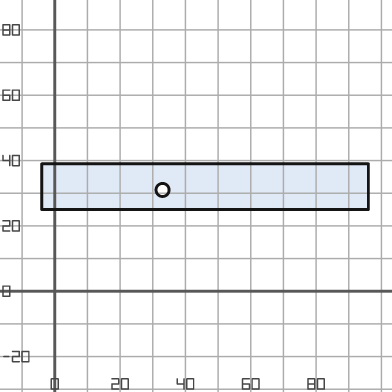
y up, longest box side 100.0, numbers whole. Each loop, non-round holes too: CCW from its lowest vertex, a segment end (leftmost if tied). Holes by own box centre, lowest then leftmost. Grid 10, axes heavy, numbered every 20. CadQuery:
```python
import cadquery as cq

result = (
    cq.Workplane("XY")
    .moveTo(-4.0, 25.0)
    .lineTo(96.0, 25.0)
    .lineTo(96.0, 39.0)
    .lineTo(-4.0, 39.0)
    .close()
    .moveTo(33.0, 31.0)
    .circle(2.0)
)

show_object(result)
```